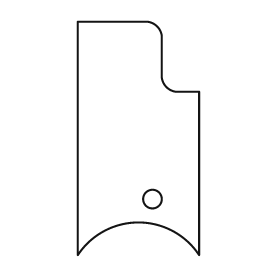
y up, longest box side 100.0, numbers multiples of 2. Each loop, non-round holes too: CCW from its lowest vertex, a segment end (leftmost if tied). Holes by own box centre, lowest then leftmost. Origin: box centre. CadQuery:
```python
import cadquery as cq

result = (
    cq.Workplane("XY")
    .moveTo(-26.0, -50.0)
    .threePointArc((0.0, -36.0), (26.0, -50.0))
    .lineTo(26.0, 20.0)
    .lineTo(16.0, 20.0)
    .threePointArc((12.0, 22.0), (10.0, 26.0))
    .lineTo(10.0, 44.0)
    .threePointArc((8.0, 48.0), (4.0, 50.0))
    .lineTo(-26.0, 50.0)
    .close()
    .moveTo(6.0, -26.0)
    .circle(4.0)
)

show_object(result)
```